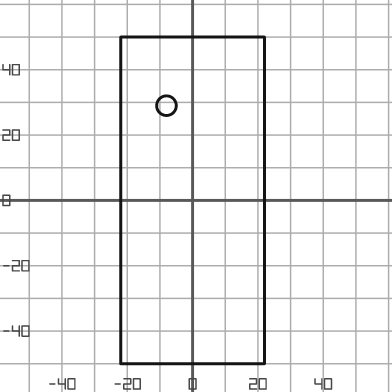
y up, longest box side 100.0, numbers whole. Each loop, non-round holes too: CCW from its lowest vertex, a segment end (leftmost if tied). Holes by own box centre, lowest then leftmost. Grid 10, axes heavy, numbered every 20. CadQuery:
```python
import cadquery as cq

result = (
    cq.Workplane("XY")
    .moveTo(-22.0, -50.0)
    .lineTo(22.0, -50.0)
    .lineTo(22.0, 50.0)
    .lineTo(-22.0, 50.0)
    .close()
    .moveTo(-8.0, 29.0)
    .circle(3.0)
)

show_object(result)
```